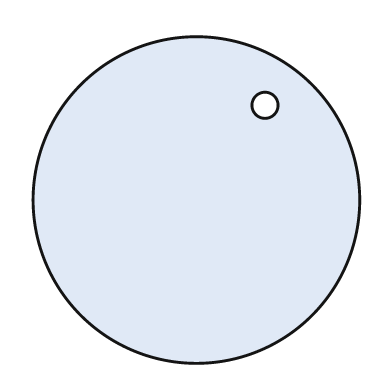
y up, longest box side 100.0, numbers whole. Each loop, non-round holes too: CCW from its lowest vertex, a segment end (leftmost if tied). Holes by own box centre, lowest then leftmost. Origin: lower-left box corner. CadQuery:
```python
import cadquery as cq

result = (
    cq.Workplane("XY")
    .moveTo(50.0, 50.0)
    .circle(50.0)
    .moveTo(71.0, 79.0)
    .circle(4.0)
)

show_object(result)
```